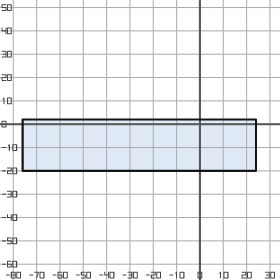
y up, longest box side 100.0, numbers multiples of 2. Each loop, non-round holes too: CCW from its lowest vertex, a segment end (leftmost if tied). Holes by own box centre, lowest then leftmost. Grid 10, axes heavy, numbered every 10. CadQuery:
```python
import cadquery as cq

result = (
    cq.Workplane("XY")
    .moveTo(-76.0, -20.0)
    .lineTo(24.0, -20.0)
    .lineTo(24.0, 2.0)
    .lineTo(-76.0, 2.0)
    .close()
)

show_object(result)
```